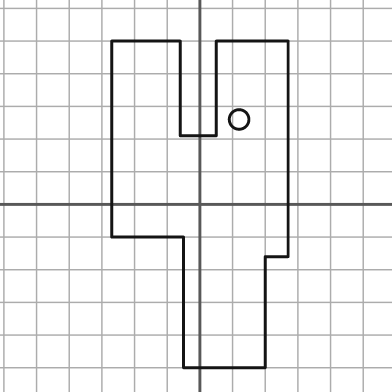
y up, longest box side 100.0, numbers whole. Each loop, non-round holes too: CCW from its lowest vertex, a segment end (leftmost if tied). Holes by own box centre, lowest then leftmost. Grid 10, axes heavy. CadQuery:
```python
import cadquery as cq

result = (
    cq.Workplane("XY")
    .moveTo(-5.0, -50.0)
    .lineTo(20.0, -50.0)
    .lineTo(20.0, -16.0)
    .lineTo(27.0, -16.0)
    .lineTo(27.0, 50.0)
    .lineTo(5.0, 50.0)
    .lineTo(5.0, 21.0)
    .lineTo(-6.0, 21.0)
    .lineTo(-6.0, 50.0)
    .lineTo(-27.0, 50.0)
    .lineTo(-27.0, -10.0)
    .lineTo(-5.0, -10.0)
    .close()
    .moveTo(12.0, 26.0)
    .circle(3.0)
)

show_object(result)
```